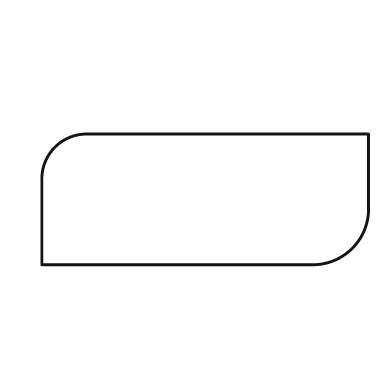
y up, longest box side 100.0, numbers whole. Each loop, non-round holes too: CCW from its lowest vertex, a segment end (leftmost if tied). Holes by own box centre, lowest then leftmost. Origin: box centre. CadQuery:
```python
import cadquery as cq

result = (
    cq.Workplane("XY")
    .moveTo(-50.0, -20.0)
    .lineTo(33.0, -20.0)
    .threePointArc((45.0, -15.0), (50.0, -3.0))
    .lineTo(50.0, 20.0)
    .lineTo(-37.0, 20.0)
    .threePointArc((-46.0, 16.0), (-50.0, 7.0))
    .close()
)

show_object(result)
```